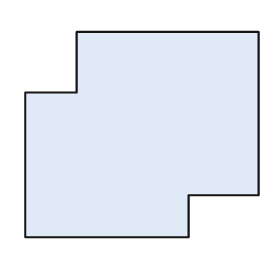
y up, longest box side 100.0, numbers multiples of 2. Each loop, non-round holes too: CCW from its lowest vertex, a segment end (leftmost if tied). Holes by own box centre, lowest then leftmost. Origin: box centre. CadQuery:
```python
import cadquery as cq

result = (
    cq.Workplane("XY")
    .moveTo(-50.0, -44.0)
    .lineTo(20.0, -44.0)
    .lineTo(20.0, -26.0)
    .lineTo(50.0, -26.0)
    .lineTo(50.0, 44.0)
    .lineTo(-28.0, 44.0)
    .lineTo(-28.0, 18.0)
    .lineTo(-50.0, 18.0)
    .close()
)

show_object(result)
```